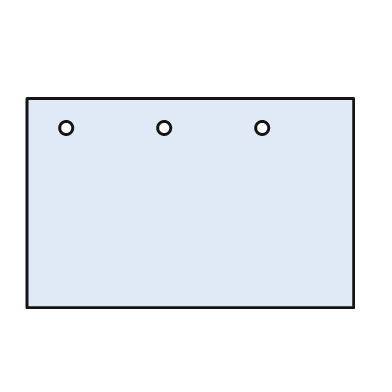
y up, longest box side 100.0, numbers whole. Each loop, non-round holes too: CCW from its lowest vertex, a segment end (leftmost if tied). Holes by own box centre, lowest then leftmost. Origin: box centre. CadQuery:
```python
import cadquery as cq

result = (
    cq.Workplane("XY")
    .moveTo(-50.0, -32.0)
    .lineTo(50.0, -32.0)
    .lineTo(50.0, 32.0)
    .lineTo(-50.0, 32.0)
    .close()
    .moveTo(-38.0, 23.0)
    .circle(2.0)
    .moveTo(-8.0, 23.0)
    .circle(2.0)
    .moveTo(22.0, 23.0)
    .circle(2.0)
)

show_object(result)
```